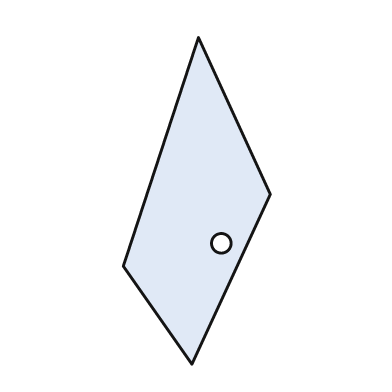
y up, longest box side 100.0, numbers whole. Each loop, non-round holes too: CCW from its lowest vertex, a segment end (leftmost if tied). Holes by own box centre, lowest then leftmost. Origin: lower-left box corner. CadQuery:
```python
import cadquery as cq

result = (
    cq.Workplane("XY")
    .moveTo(21.0, 0.0)
    .lineTo(45.0, 52.0)
    .lineTo(23.0, 100.0)
    .lineTo(0.0, 30.0)
    .close()
    .moveTo(30.0, 37.0)
    .circle(3.0)
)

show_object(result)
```